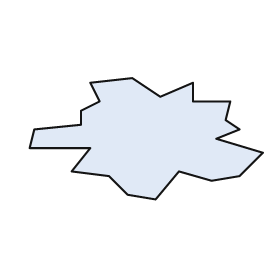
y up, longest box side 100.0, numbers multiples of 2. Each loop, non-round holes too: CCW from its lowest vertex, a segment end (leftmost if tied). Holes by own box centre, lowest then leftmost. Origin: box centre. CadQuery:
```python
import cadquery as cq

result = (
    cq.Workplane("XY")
    .moveTo(4.0, -26.0)
    .lineTo(14.0, -14.0)
    .lineTo(28.0, -18.0)
    .lineTo(40.0, -16.0)
    .lineTo(50.0, -6.0)
    .lineTo(30.0, 0.0)
    .lineTo(40.0, 4.0)
    .lineTo(34.0, 8.0)
    .lineTo(36.0, 16.0)
    .lineTo(20.0, 16.0)
    .lineTo(20.0, 24.0)
    .lineTo(6.0, 18.0)
    .lineTo(-6.0, 26.0)
    .lineTo(-24.0, 24.0)
    .lineTo(-20.0, 16.0)
    .lineTo(-28.0, 12.0)
    .lineTo(-28.0, 6.0)
    .lineTo(-48.0, 4.0)
    .lineTo(-50.0, -4.0)
    .lineTo(-24.0, -4.0)
    .lineTo(-32.0, -14.0)
    .lineTo(-16.0, -16.0)
    .lineTo(-8.0, -24.0)
    .close()
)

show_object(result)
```